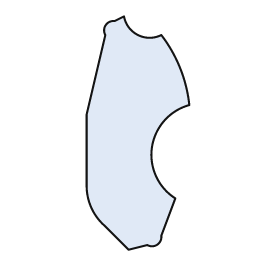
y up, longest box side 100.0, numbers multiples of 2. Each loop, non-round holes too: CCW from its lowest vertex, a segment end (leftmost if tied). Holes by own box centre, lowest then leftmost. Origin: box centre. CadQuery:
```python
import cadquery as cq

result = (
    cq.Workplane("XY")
    .moveTo(-4.0, -50.0)
    .lineTo(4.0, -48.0)
    .threePointArc((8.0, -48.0), (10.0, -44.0))
    .lineTo(16.0, -28.0)
    .threePointArc((6.0, -6.0), (22.0, 12.0))
    .threePointArc((18.0, 28.0), (10.0, 42.0))
    .threePointArc((0.0, 42.0), (-6.0, 50.0))
    .lineTo(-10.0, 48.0)
    .threePointArc((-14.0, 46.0), (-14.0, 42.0))
    .lineTo(-22.0, 8.0)
    .lineTo(-22.0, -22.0)
    .threePointArc((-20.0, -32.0), (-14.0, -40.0))
    .close()
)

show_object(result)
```